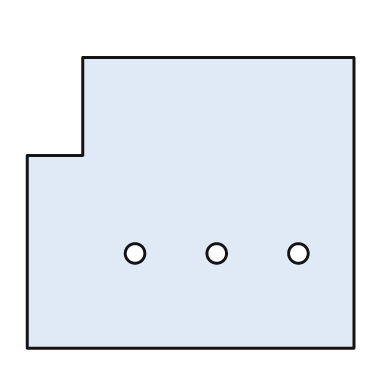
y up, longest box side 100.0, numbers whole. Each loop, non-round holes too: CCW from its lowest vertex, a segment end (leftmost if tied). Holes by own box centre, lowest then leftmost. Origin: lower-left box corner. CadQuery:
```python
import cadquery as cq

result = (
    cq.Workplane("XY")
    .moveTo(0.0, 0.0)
    .lineTo(100.0, 0.0)
    .lineTo(100.0, 89.0)
    .lineTo(17.0, 89.0)
    .lineTo(17.0, 59.0)
    .lineTo(0.0, 59.0)
    .close()
    .moveTo(33.0, 29.0)
    .circle(3.0)
    .moveTo(58.0, 29.0)
    .circle(3.0)
    .moveTo(83.0, 29.0)
    .circle(3.0)
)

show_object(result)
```